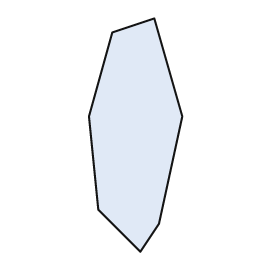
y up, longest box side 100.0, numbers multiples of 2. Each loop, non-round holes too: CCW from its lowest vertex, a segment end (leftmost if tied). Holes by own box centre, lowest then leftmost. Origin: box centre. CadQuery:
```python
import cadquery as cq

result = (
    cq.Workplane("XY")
    .moveTo(2.0, -50.0)
    .lineTo(10.0, -38.0)
    .lineTo(20.0, 8.0)
    .lineTo(8.0, 50.0)
    .lineTo(-10.0, 44.0)
    .lineTo(-20.0, 8.0)
    .lineTo(-16.0, -32.0)
    .close()
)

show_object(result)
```